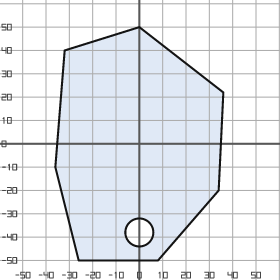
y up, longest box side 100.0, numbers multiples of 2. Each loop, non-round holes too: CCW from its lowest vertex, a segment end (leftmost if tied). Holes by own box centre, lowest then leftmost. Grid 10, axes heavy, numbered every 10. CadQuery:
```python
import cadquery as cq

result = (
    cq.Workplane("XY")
    .moveTo(-26.0, -50.0)
    .lineTo(8.0, -50.0)
    .lineTo(34.0, -20.0)
    .lineTo(36.0, 22.0)
    .lineTo(0.0, 50.0)
    .lineTo(-32.0, 40.0)
    .lineTo(-36.0, -10.0)
    .close()
    .moveTo(0.0, -38.0)
    .circle(6.0)
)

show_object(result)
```